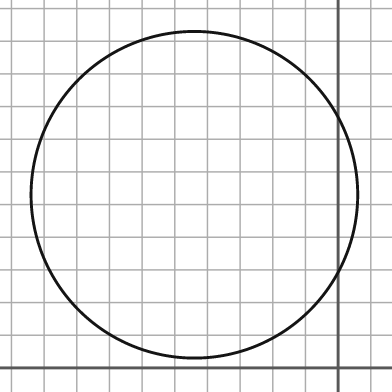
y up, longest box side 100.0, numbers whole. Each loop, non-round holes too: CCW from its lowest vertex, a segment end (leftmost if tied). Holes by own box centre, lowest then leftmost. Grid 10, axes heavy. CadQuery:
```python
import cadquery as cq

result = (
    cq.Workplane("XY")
    .moveTo(-44.0, 53.0)
    .circle(50.0)
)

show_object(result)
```